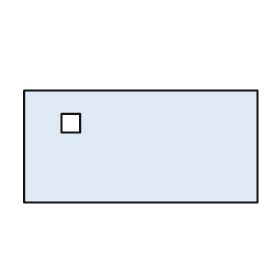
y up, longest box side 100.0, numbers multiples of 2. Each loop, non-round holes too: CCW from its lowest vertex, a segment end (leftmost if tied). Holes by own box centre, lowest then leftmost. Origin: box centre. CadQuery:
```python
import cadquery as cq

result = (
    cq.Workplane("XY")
    .moveTo(-50.0, -24.0)
    .lineTo(50.0, -24.0)
    .lineTo(50.0, 24.0)
    .lineTo(-50.0, 24.0)
    .close()
    .moveTo(-34.0, 6.0)
    .lineTo(-26.0, 6.0)
    .lineTo(-26.0, 14.0)
    .lineTo(-34.0, 14.0)
    .close()
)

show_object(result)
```